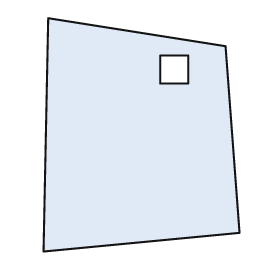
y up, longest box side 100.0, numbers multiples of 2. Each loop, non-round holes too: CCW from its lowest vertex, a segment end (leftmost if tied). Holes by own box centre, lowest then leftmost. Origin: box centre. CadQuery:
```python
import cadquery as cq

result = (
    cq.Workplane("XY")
    .moveTo(-42.0, -50.0)
    .lineTo(42.0, -42.0)
    .lineTo(36.0, 38.0)
    .lineTo(-40.0, 50.0)
    .close()
    .moveTo(8.0, 22.0)
    .lineTo(20.0, 22.0)
    .lineTo(20.0, 34.0)
    .lineTo(8.0, 34.0)
    .close()
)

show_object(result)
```